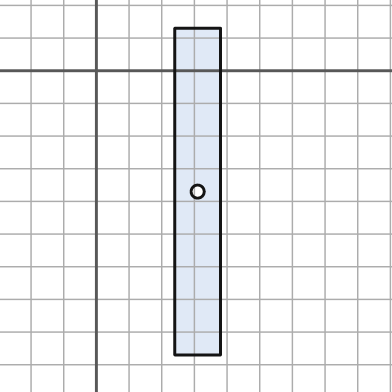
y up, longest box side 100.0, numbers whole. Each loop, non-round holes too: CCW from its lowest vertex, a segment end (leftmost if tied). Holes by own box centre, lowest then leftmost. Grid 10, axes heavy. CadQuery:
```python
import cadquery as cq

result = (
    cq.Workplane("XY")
    .moveTo(24.0, -87.0)
    .lineTo(38.0, -87.0)
    .lineTo(38.0, 13.0)
    .lineTo(24.0, 13.0)
    .close()
    .moveTo(31.0, -37.0)
    .circle(2.0)
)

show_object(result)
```